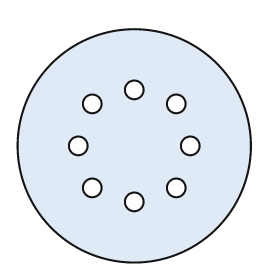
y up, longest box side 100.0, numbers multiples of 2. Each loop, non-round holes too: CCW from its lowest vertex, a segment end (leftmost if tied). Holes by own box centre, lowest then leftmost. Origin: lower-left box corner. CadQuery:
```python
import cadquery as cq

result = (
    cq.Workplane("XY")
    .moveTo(50.0, 50.0)
    .circle(50.0)
    .moveTo(50.0, 26.0)
    .circle(4.0)
    .moveTo(32.0, 32.0)
    .circle(4.0)
    .moveTo(68.0, 32.0)
    .circle(4.0)
    .moveTo(26.0, 50.0)
    .circle(4.0)
    .moveTo(74.0, 50.0)
    .circle(4.0)
    .moveTo(32.0, 68.0)
    .circle(4.0)
    .moveTo(68.0, 68.0)
    .circle(4.0)
    .moveTo(50.0, 74.0)
    .circle(4.0)
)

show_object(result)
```